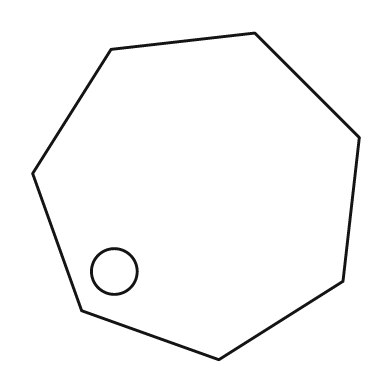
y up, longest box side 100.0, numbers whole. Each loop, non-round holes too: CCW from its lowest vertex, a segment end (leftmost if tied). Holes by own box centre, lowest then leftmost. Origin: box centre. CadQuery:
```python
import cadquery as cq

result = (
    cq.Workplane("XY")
    .moveTo(7.0, -50.0)
    .lineTo(45.0, -26.0)
    .lineTo(50.0, 18.0)
    .lineTo(18.0, 50.0)
    .lineTo(-26.0, 45.0)
    .lineTo(-50.0, 7.0)
    .lineTo(-35.0, -35.0)
    .close()
    .moveTo(-25.0, -23.0)
    .circle(7.0)
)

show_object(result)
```